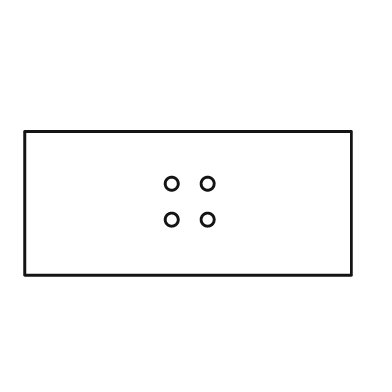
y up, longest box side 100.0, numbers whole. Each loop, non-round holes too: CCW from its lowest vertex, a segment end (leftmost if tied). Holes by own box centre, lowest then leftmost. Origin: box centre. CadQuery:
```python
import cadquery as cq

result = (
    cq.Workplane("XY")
    .moveTo(-50.0, -22.0)
    .lineTo(50.0, -22.0)
    .lineTo(50.0, 22.0)
    .lineTo(-50.0, 22.0)
    .close()
    .moveTo(-5.0, -5.0)
    .circle(2.0)
    .moveTo(6.0, -5.0)
    .circle(2.0)
    .moveTo(-5.0, 6.0)
    .circle(2.0)
    .moveTo(6.0, 6.0)
    .circle(2.0)
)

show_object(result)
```